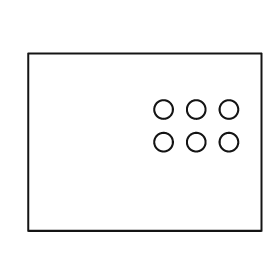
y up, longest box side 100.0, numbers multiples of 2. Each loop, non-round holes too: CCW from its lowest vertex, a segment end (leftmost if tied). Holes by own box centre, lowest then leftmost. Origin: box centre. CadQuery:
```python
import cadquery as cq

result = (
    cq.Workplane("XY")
    .moveTo(-50.0, -38.0)
    .lineTo(50.0, -38.0)
    .lineTo(50.0, 38.0)
    .lineTo(-50.0, 38.0)
    .close()
    .moveTo(8.0, 0.0)
    .circle(4.0)
    .moveTo(22.0, 0.0)
    .circle(4.0)
    .moveTo(36.0, 0.0)
    .circle(4.0)
    .moveTo(8.0, 14.0)
    .circle(4.0)
    .moveTo(22.0, 14.0)
    .circle(4.0)
    .moveTo(36.0, 14.0)
    .circle(4.0)
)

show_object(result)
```